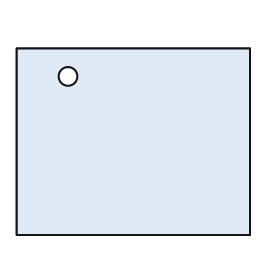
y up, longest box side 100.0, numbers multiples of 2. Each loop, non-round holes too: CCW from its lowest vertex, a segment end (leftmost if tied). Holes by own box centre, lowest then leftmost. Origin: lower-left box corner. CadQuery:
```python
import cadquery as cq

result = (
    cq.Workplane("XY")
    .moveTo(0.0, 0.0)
    .lineTo(100.0, 0.0)
    .lineTo(100.0, 80.0)
    .lineTo(0.0, 80.0)
    .close()
    .moveTo(22.0, 68.0)
    .circle(4.0)
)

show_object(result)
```